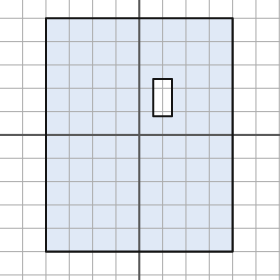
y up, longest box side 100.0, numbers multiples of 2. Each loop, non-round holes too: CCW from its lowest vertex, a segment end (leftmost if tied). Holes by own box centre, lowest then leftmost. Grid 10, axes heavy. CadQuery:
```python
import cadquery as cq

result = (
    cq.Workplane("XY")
    .moveTo(-40.0, -50.0)
    .lineTo(40.0, -50.0)
    .lineTo(40.0, 50.0)
    .lineTo(-40.0, 50.0)
    .close()
    .moveTo(6.0, 8.0)
    .lineTo(14.0, 8.0)
    .lineTo(14.0, 24.0)
    .lineTo(6.0, 24.0)
    .close()
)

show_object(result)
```